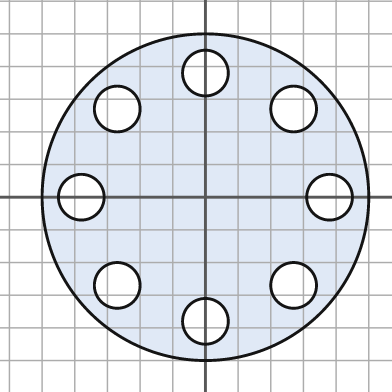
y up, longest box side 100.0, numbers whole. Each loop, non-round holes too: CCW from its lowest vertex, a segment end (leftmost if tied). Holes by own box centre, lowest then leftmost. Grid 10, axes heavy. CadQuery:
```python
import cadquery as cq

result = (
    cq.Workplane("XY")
    .moveTo(0.0, 0.0)
    .circle(50.0)
    .moveTo(0.0, -38.0)
    .circle(7.0)
    .moveTo(-27.0, -27.0)
    .circle(7.0)
    .moveTo(27.0, -27.0)
    .circle(7.0)
    .moveTo(-38.0, 0.0)
    .circle(7.0)
    .moveTo(38.0, 0.0)
    .circle(7.0)
    .moveTo(-27.0, 27.0)
    .circle(7.0)
    .moveTo(27.0, 27.0)
    .circle(7.0)
    .moveTo(0.0, 38.0)
    .circle(7.0)
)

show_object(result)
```